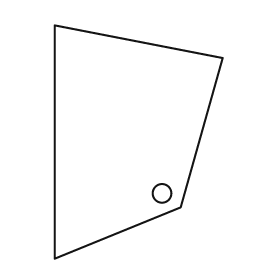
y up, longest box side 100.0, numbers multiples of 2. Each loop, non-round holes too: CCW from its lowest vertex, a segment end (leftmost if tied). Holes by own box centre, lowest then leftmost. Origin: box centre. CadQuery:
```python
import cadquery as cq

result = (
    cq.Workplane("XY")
    .moveTo(-36.0, -50.0)
    .lineTo(18.0, -28.0)
    .lineTo(36.0, 36.0)
    .lineTo(-36.0, 50.0)
    .close()
    .moveTo(10.0, -22.0)
    .circle(4.0)
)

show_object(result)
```